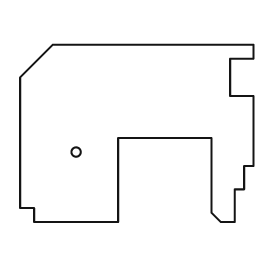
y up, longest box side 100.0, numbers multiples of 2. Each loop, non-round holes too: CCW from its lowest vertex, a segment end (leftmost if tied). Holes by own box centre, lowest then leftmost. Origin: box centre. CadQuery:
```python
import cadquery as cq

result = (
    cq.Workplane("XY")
    .moveTo(-44.0, -38.0)
    .lineTo(-8.0, -38.0)
    .lineTo(-8.0, -2.0)
    .lineTo(32.0, -2.0)
    .lineTo(32.0, -34.0)
    .lineTo(36.0, -38.0)
    .lineTo(42.0, -38.0)
    .lineTo(42.0, -24.0)
    .lineTo(46.0, -24.0)
    .lineTo(46.0, -14.0)
    .lineTo(50.0, -14.0)
    .lineTo(50.0, 16.0)
    .lineTo(40.0, 16.0)
    .lineTo(40.0, 32.0)
    .lineTo(50.0, 32.0)
    .lineTo(50.0, 38.0)
    .lineTo(-36.0, 38.0)
    .lineTo(-50.0, 24.0)
    .lineTo(-50.0, -32.0)
    .lineTo(-44.0, -32.0)
    .close()
    .moveTo(-26.0, -8.0)
    .circle(2.0)
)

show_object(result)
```